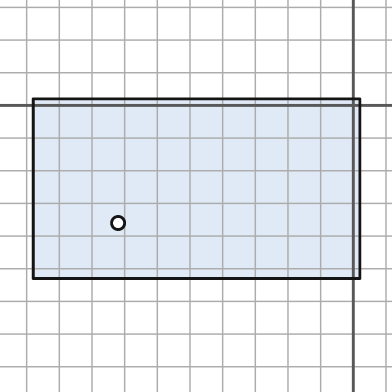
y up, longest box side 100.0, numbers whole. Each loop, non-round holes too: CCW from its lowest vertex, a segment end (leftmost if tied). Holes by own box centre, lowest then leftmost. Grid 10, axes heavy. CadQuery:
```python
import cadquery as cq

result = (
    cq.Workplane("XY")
    .moveTo(-98.0, -53.0)
    .lineTo(2.0, -53.0)
    .lineTo(2.0, 2.0)
    .lineTo(-98.0, 2.0)
    .close()
    .moveTo(-72.0, -36.0)
    .circle(2.0)
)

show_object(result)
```